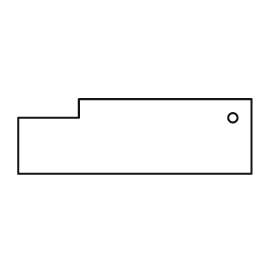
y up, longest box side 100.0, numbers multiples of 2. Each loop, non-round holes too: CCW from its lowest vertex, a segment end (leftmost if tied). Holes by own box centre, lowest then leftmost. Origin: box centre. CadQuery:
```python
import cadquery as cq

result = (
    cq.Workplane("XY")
    .moveTo(-50.0, -16.0)
    .lineTo(50.0, -16.0)
    .lineTo(50.0, 16.0)
    .lineTo(-24.0, 16.0)
    .lineTo(-24.0, 8.0)
    .lineTo(-50.0, 8.0)
    .close()
    .moveTo(42.0, 8.0)
    .circle(2.0)
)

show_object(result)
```